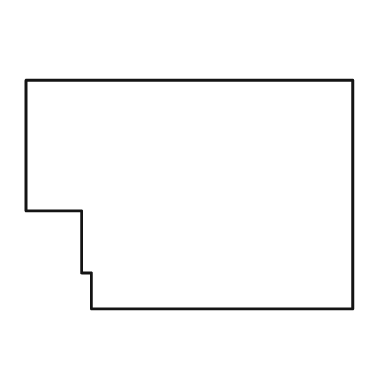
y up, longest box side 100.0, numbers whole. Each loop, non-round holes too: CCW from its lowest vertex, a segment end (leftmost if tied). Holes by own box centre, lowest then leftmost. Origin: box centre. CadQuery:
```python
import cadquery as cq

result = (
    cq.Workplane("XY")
    .moveTo(-30.0, -35.0)
    .lineTo(50.0, -35.0)
    .lineTo(50.0, 35.0)
    .lineTo(-50.0, 35.0)
    .lineTo(-50.0, -5.0)
    .lineTo(-33.0, -5.0)
    .lineTo(-33.0, -24.0)
    .lineTo(-30.0, -24.0)
    .close()
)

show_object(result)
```